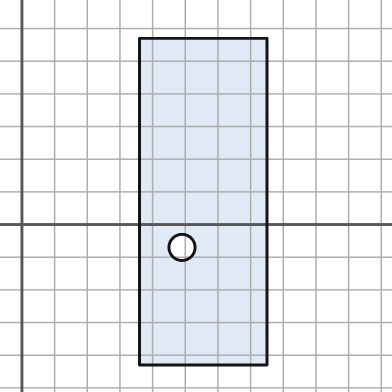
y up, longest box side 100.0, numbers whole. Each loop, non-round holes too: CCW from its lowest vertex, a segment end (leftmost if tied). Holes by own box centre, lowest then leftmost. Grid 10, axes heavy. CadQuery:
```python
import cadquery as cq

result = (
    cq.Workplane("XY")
    .moveTo(36.0, -43.0)
    .lineTo(75.0, -43.0)
    .lineTo(75.0, 57.0)
    .lineTo(36.0, 57.0)
    .close()
    .moveTo(49.0, -7.0)
    .circle(4.0)
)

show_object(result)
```